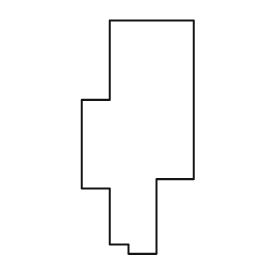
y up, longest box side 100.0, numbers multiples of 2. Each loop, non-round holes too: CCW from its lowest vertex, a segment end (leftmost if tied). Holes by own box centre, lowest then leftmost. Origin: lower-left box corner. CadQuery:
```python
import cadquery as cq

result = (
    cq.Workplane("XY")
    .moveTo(20.0, 0.0)
    .lineTo(32.0, 0.0)
    .lineTo(32.0, 32.0)
    .lineTo(48.0, 32.0)
    .lineTo(48.0, 100.0)
    .lineTo(12.0, 100.0)
    .lineTo(12.0, 66.0)
    .lineTo(0.0, 66.0)
    .lineTo(0.0, 28.0)
    .lineTo(12.0, 28.0)
    .lineTo(12.0, 4.0)
    .lineTo(20.0, 4.0)
    .close()
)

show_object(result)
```